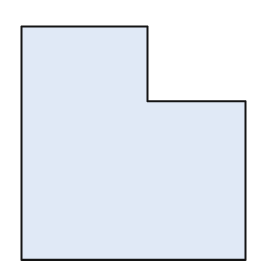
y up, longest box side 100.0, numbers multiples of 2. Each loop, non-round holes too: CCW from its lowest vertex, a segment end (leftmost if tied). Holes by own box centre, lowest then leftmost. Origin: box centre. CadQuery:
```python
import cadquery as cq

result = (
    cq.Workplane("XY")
    .moveTo(-48.0, -50.0)
    .lineTo(48.0, -50.0)
    .lineTo(48.0, 18.0)
    .lineTo(6.0, 18.0)
    .lineTo(6.0, 50.0)
    .lineTo(-48.0, 50.0)
    .close()
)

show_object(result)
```